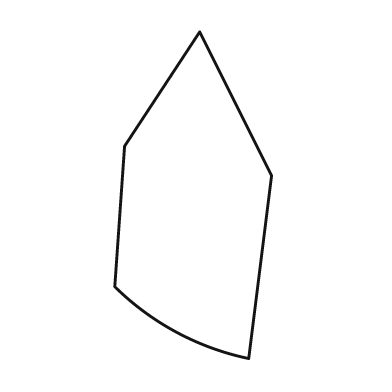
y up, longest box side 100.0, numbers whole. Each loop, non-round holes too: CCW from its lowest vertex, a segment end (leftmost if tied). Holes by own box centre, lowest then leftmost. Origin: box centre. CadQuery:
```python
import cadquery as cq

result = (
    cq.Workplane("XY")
    .moveTo(17.0, -50.0)
    .lineTo(24.0, 6.0)
    .lineTo(2.0, 50.0)
    .lineTo(-21.0, 15.0)
    .lineTo(-24.0, -28.0)
    .threePointArc((-5.0, -42.0), (17.0, -50.0))
    .close()
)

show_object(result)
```